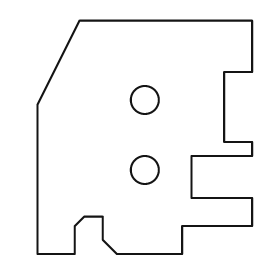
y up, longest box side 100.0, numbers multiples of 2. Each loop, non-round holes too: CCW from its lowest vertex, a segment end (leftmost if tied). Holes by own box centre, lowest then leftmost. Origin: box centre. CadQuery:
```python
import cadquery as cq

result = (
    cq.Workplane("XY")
    .moveTo(-46.0, -50.0)
    .lineTo(-30.0, -50.0)
    .lineTo(-30.0, -38.0)
    .lineTo(-26.0, -34.0)
    .lineTo(-18.0, -34.0)
    .lineTo(-18.0, -44.0)
    .lineTo(-12.0, -50.0)
    .lineTo(16.0, -50.0)
    .lineTo(16.0, -38.0)
    .lineTo(46.0, -38.0)
    .lineTo(46.0, -26.0)
    .lineTo(20.0, -26.0)
    .lineTo(20.0, -8.0)
    .lineTo(46.0, -8.0)
    .lineTo(46.0, -2.0)
    .lineTo(34.0, -2.0)
    .lineTo(34.0, 28.0)
    .lineTo(46.0, 28.0)
    .lineTo(46.0, 50.0)
    .lineTo(-28.0, 50.0)
    .lineTo(-46.0, 14.0)
    .close()
    .moveTo(0.0, -14.0)
    .circle(6.0)
    .moveTo(0.0, 16.0)
    .circle(6.0)
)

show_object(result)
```